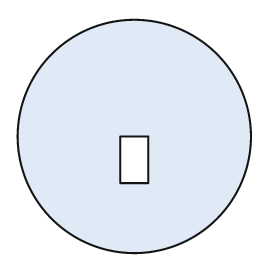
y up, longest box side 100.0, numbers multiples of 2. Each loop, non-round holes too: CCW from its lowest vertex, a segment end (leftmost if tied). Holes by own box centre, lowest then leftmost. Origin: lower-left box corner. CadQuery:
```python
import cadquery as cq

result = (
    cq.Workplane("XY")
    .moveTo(50.0, 50.0)
    .circle(50.0)
    .moveTo(44.0, 30.0)
    .lineTo(56.0, 30.0)
    .lineTo(56.0, 50.0)
    .lineTo(44.0, 50.0)
    .close()
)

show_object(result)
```